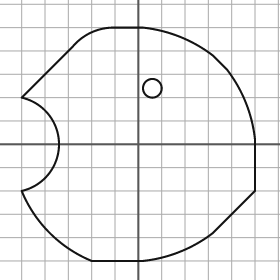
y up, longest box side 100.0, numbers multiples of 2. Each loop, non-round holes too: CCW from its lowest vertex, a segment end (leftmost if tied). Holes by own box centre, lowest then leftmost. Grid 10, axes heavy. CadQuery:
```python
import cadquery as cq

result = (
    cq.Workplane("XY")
    .moveTo(-20.0, -50.0)
    .lineTo(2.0, -50.0)
    .threePointArc((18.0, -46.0), (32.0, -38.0))
    .lineTo(50.0, -20.0)
    .lineTo(50.0, 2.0)
    .threePointArc((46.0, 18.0), (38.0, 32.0))
    .lineTo(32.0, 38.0)
    .threePointArc((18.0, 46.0), (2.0, 50.0))
    .lineTo(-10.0, 50.0)
    .threePointArc((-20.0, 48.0), (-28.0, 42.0))
    .lineTo(-50.0, 20.0)
    .threePointArc((-34.0, 0.0), (-50.0, -20.0))
    .threePointArc((-38.0, -38.0), (-20.0, -50.0))
    .close()
    .moveTo(6.0, 24.0)
    .circle(4.0)
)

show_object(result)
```